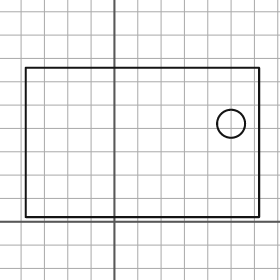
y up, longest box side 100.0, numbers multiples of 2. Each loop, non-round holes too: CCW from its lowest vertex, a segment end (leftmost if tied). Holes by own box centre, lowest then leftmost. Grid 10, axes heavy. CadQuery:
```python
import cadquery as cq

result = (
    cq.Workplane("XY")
    .moveTo(-38.0, 2.0)
    .lineTo(62.0, 2.0)
    .lineTo(62.0, 66.0)
    .lineTo(-38.0, 66.0)
    .close()
    .moveTo(50.0, 42.0)
    .circle(6.0)
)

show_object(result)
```